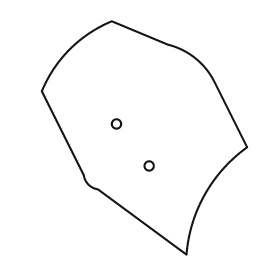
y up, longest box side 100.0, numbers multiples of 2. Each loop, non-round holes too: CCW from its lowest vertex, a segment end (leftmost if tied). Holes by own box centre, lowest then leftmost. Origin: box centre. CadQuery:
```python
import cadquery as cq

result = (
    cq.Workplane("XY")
    .moveTo(18.0, -50.0)
    .threePointArc((26.0, -24.0), (44.0, -4.0))
    .lineTo(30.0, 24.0)
    .threePointArc((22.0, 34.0), (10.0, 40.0))
    .lineTo(-14.0, 50.0)
    .threePointArc((-32.0, 38.0), (-44.0, 20.0))
    .lineTo(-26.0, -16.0)
    .threePointArc((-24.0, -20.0), (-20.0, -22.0))
    .close()
    .moveTo(2.0, -12.0)
    .circle(2.0)
    .moveTo(-12.0, 6.0)
    .circle(2.0)
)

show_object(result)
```